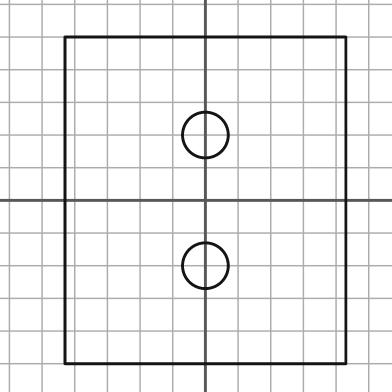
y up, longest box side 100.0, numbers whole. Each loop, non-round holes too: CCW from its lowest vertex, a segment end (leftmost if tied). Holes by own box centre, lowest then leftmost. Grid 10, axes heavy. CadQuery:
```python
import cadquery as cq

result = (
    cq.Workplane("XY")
    .moveTo(-43.0, -50.0)
    .lineTo(43.0, -50.0)
    .lineTo(43.0, 50.0)
    .lineTo(-43.0, 50.0)
    .close()
    .moveTo(0.0, -20.0)
    .circle(7.0)
    .moveTo(0.0, 20.0)
    .circle(7.0)
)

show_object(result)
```